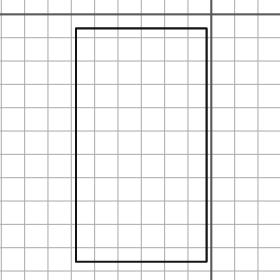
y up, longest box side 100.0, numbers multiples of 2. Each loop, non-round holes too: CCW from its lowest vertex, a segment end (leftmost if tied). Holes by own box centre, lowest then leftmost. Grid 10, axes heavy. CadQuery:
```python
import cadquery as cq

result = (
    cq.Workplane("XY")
    .moveTo(-58.0, -106.0)
    .lineTo(-2.0, -106.0)
    .lineTo(-2.0, -6.0)
    .lineTo(-58.0, -6.0)
    .close()
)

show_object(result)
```